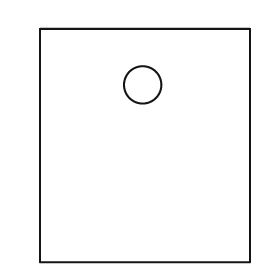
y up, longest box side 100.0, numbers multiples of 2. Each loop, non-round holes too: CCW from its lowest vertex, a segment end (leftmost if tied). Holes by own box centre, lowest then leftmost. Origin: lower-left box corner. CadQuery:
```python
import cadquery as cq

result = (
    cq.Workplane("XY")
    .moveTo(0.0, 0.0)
    .lineTo(90.0, 0.0)
    .lineTo(90.0, 100.0)
    .lineTo(0.0, 100.0)
    .close()
    .moveTo(44.0, 76.0)
    .circle(8.0)
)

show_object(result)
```